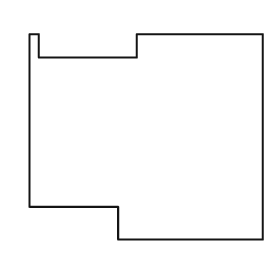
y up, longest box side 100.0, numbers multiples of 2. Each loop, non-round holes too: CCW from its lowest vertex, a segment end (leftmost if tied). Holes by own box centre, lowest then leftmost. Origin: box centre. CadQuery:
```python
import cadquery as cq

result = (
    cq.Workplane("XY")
    .moveTo(-12.0, -44.0)
    .lineTo(50.0, -44.0)
    .lineTo(50.0, 44.0)
    .lineTo(-4.0, 44.0)
    .lineTo(-4.0, 34.0)
    .lineTo(-46.0, 34.0)
    .lineTo(-46.0, 44.0)
    .lineTo(-50.0, 44.0)
    .lineTo(-50.0, -30.0)
    .lineTo(-12.0, -30.0)
    .close()
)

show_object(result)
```